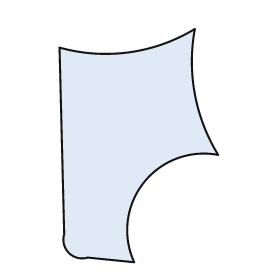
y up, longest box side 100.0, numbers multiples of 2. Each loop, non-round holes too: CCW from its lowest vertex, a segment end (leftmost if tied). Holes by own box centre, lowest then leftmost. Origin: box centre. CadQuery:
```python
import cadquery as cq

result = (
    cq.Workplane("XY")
    .moveTo(-2.0, -50.0)
    .threePointArc((2.0, -16.0), (34.0, -4.0))
    .threePointArc((24.0, 22.0), (24.0, 50.0))
    .threePointArc((-4.0, 40.0), (-34.0, 42.0))
    .lineTo(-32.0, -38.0)
    .threePointArc((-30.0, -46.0), (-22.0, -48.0))
    .close()
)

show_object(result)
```